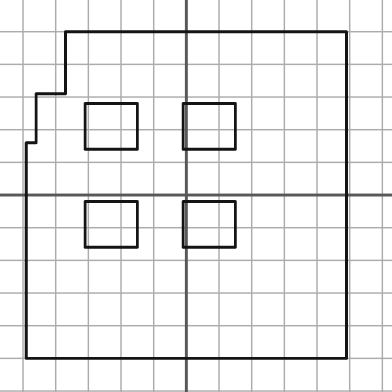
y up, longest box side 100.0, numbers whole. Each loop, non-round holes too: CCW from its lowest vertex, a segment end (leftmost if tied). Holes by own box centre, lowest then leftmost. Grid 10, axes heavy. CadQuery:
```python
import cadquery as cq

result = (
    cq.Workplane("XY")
    .moveTo(-49.0, -50.0)
    .lineTo(49.0, -50.0)
    .lineTo(49.0, 50.0)
    .lineTo(-37.0, 50.0)
    .lineTo(-37.0, 31.0)
    .lineTo(-46.0, 31.0)
    .lineTo(-46.0, 16.0)
    .lineTo(-49.0, 16.0)
    .close()
    .moveTo(-31.0, -16.0)
    .lineTo(-15.0, -16.0)
    .lineTo(-15.0, -2.0)
    .lineTo(-31.0, -2.0)
    .close()
    .moveTo(-1.0, -16.0)
    .lineTo(15.0, -16.0)
    .lineTo(15.0, -2.0)
    .lineTo(-1.0, -2.0)
    .close()
    .moveTo(-31.0, 14.0)
    .lineTo(-15.0, 14.0)
    .lineTo(-15.0, 28.0)
    .lineTo(-31.0, 28.0)
    .close()
    .moveTo(-1.0, 14.0)
    .lineTo(15.0, 14.0)
    .lineTo(15.0, 28.0)
    .lineTo(-1.0, 28.0)
    .close()
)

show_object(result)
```